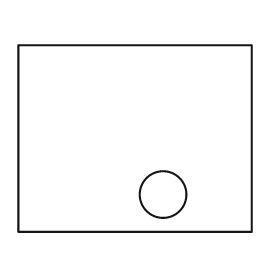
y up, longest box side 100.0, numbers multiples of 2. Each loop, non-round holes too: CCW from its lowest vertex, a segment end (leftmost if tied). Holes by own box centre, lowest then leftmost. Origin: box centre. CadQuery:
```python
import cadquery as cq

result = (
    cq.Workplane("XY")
    .moveTo(-50.0, -40.0)
    .lineTo(50.0, -40.0)
    .lineTo(50.0, 40.0)
    .lineTo(-50.0, 40.0)
    .close()
    .moveTo(12.0, -24.0)
    .circle(10.0)
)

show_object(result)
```